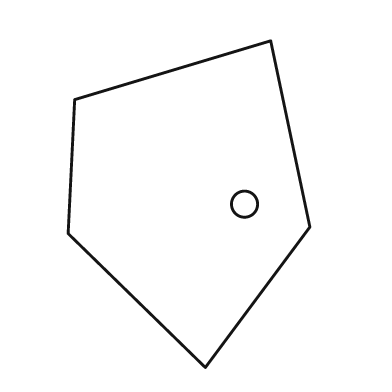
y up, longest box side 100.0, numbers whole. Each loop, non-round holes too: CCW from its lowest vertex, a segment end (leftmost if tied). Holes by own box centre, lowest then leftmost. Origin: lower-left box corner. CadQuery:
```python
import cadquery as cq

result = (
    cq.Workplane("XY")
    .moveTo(42.0, 0.0)
    .lineTo(74.0, 43.0)
    .lineTo(62.0, 100.0)
    .lineTo(2.0, 82.0)
    .lineTo(0.0, 41.0)
    .close()
    .moveTo(54.0, 50.0)
    .circle(4.0)
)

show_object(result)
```